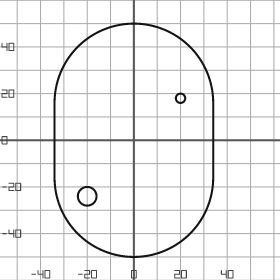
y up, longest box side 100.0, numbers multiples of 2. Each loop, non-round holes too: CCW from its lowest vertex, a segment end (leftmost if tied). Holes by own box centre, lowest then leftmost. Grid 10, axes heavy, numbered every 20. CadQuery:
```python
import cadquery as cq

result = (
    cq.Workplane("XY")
    .moveTo(-34.0, -16.0)
    .threePointArc((0.0, -50.0), (34.0, -16.0))
    .lineTo(34.0, 16.0)
    .threePointArc((0.0, 50.0), (-34.0, 16.0))
    .close()
    .moveTo(-20.0, -24.0)
    .circle(4.0)
    .moveTo(20.0, 18.0)
    .circle(2.0)
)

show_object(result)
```